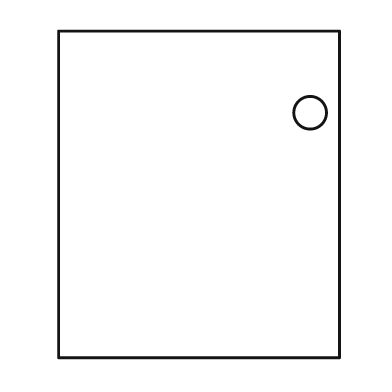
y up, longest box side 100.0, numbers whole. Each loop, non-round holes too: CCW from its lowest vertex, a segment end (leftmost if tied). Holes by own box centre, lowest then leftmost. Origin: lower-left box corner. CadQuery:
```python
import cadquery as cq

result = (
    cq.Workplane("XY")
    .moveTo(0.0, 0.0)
    .lineTo(86.0, 0.0)
    .lineTo(86.0, 100.0)
    .lineTo(0.0, 100.0)
    .close()
    .moveTo(77.0, 75.0)
    .circle(5.0)
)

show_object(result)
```